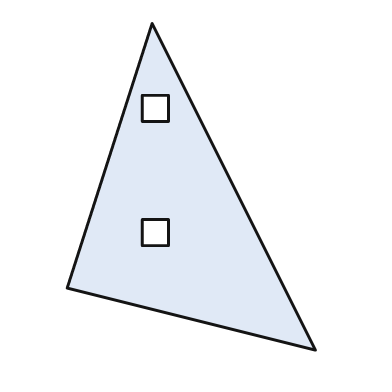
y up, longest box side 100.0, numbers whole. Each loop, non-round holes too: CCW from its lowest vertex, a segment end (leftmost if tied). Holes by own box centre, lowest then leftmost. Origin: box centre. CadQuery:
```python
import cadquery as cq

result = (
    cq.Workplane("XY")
    .moveTo(38.0, -50.0)
    .lineTo(-12.0, 50.0)
    .lineTo(-38.0, -31.0)
    .close()
    .moveTo(-15.0, -18.0)
    .lineTo(-7.0, -18.0)
    .lineTo(-7.0, -10.0)
    .lineTo(-15.0, -10.0)
    .close()
    .moveTo(-15.0, 20.0)
    .lineTo(-7.0, 20.0)
    .lineTo(-7.0, 28.0)
    .lineTo(-15.0, 28.0)
    .close()
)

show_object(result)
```